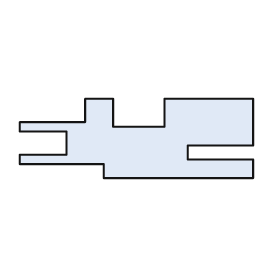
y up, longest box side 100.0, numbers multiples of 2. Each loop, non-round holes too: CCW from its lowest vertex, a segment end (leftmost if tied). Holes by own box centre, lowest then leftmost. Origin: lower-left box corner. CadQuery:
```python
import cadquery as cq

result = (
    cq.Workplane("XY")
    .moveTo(36.0, 0.0)
    .lineTo(100.0, 0.0)
    .lineTo(100.0, 8.0)
    .lineTo(72.0, 8.0)
    .lineTo(72.0, 14.0)
    .lineTo(100.0, 14.0)
    .lineTo(100.0, 34.0)
    .lineTo(62.0, 34.0)
    .lineTo(62.0, 22.0)
    .lineTo(40.0, 22.0)
    .lineTo(40.0, 34.0)
    .lineTo(28.0, 34.0)
    .lineTo(28.0, 24.0)
    .lineTo(0.0, 24.0)
    .lineTo(0.0, 20.0)
    .lineTo(20.0, 20.0)
    .lineTo(20.0, 10.0)
    .lineTo(0.0, 10.0)
    .lineTo(0.0, 6.0)
    .lineTo(36.0, 6.0)
    .close()
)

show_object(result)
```